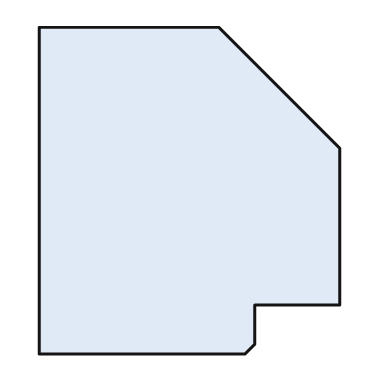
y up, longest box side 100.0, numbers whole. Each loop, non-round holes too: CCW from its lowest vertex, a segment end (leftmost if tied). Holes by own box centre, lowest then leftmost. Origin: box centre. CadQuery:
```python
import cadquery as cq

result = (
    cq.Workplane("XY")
    .moveTo(-46.0, -50.0)
    .lineTo(17.0, -50.0)
    .lineTo(20.0, -47.0)
    .lineTo(20.0, -35.0)
    .lineTo(46.0, -35.0)
    .lineTo(46.0, 13.0)
    .lineTo(9.0, 50.0)
    .lineTo(-46.0, 50.0)
    .close()
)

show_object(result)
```